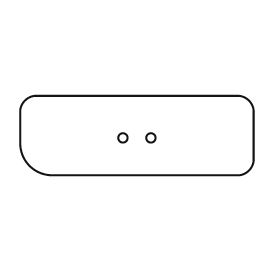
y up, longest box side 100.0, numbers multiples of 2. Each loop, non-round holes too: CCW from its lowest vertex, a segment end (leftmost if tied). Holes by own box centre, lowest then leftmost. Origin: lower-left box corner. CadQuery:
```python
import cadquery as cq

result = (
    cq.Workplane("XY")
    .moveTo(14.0, 0.0)
    .lineTo(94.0, 0.0)
    .threePointArc((98.0, 2.0), (100.0, 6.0))
    .lineTo(100.0, 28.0)
    .threePointArc((98.0, 32.0), (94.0, 34.0))
    .lineTo(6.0, 34.0)
    .threePointArc((2.0, 32.0), (0.0, 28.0))
    .lineTo(0.0, 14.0)
    .threePointArc((4.0, 4.0), (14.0, 0.0))
    .close()
    .moveTo(44.0, 16.0)
    .circle(2.0)
    .moveTo(56.0, 16.0)
    .circle(2.0)
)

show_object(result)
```